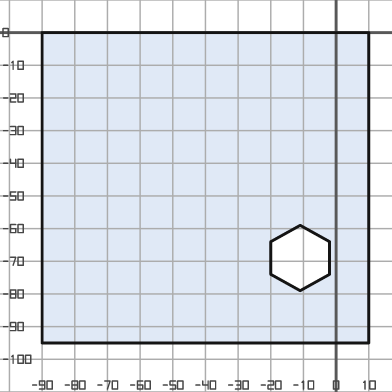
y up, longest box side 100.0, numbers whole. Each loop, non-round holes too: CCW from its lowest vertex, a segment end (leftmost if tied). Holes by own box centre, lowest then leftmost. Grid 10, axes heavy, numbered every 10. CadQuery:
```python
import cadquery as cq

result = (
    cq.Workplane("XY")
    .moveTo(-90.0, -95.0)
    .lineTo(10.0, -95.0)
    .lineTo(10.0, 0.0)
    .lineTo(-90.0, 0.0)
    .close()
    .moveTo(-11.0, -79.0)
    .lineTo(-2.0, -74.0)
    .lineTo(-2.0, -64.0)
    .lineTo(-11.0, -59.0)
    .lineTo(-20.0, -64.0)
    .lineTo(-20.0, -74.0)
    .close()
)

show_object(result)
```